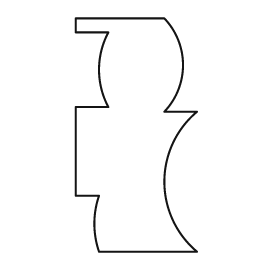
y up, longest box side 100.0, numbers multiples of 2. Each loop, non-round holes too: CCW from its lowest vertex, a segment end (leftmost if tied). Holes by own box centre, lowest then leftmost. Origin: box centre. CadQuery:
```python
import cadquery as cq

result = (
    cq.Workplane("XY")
    .moveTo(-16.0, -50.0)
    .lineTo(26.0, -50.0)
    .threePointArc((12.0, -20.0), (26.0, 10.0))
    .lineTo(12.0, 10.0)
    .threePointArc((20.0, 30.0), (12.0, 50.0))
    .lineTo(-26.0, 50.0)
    .lineTo(-26.0, 44.0)
    .lineTo(-12.0, 44.0)
    .threePointArc((-16.0, 28.0), (-12.0, 12.0))
    .lineTo(-26.0, 12.0)
    .lineTo(-26.0, -26.0)
    .lineTo(-16.0, -26.0)
    .threePointArc((-18.0, -38.0), (-16.0, -50.0))
    .close()
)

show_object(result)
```